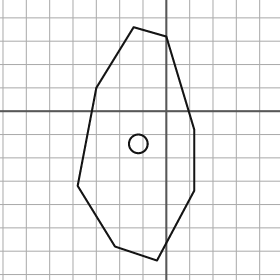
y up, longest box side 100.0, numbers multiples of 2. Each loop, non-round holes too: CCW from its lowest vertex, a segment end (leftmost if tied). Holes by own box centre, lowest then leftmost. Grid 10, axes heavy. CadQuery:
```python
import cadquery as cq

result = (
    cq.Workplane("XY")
    .moveTo(-4.0, -64.0)
    .lineTo(12.0, -34.0)
    .lineTo(12.0, -8.0)
    .lineTo(0.0, 32.0)
    .lineTo(-14.0, 36.0)
    .lineTo(-30.0, 10.0)
    .lineTo(-38.0, -32.0)
    .lineTo(-22.0, -58.0)
    .close()
    .moveTo(-12.0, -14.0)
    .circle(4.0)
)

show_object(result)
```